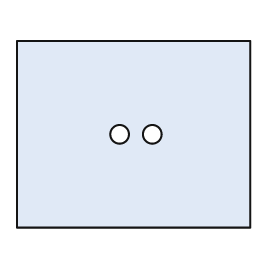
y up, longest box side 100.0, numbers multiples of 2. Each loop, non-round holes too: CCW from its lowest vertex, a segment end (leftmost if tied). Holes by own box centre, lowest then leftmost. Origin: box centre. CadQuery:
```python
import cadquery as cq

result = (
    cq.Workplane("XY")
    .moveTo(-50.0, -40.0)
    .lineTo(50.0, -40.0)
    .lineTo(50.0, 40.0)
    .lineTo(-50.0, 40.0)
    .close()
    .moveTo(-6.0, 0.0)
    .circle(4.0)
    .moveTo(8.0, 0.0)
    .circle(4.0)
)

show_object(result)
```